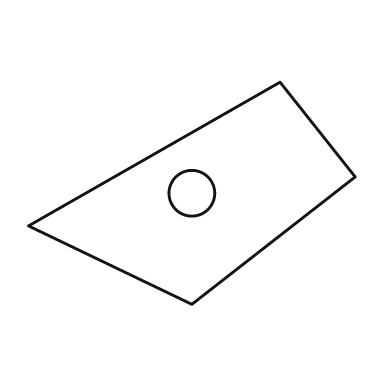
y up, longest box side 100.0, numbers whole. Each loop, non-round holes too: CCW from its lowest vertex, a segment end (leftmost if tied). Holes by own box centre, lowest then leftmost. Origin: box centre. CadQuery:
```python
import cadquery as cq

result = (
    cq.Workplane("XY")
    .moveTo(0.0, -34.0)
    .lineTo(50.0, 5.0)
    .lineTo(27.0, 34.0)
    .lineTo(-50.0, -10.0)
    .close()
    .moveTo(0.0, 0.0)
    .circle(7.0)
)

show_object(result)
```